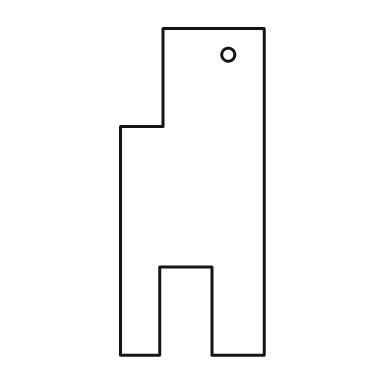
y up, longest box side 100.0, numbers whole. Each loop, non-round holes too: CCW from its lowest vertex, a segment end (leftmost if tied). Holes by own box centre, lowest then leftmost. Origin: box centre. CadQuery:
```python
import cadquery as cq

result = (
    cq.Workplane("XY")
    .moveTo(-22.0, -50.0)
    .lineTo(-10.0, -50.0)
    .lineTo(-10.0, -23.0)
    .lineTo(6.0, -23.0)
    .lineTo(6.0, -50.0)
    .lineTo(22.0, -50.0)
    .lineTo(22.0, 50.0)
    .lineTo(-9.0, 50.0)
    .lineTo(-9.0, 20.0)
    .lineTo(-22.0, 20.0)
    .close()
    .moveTo(11.0, 42.0)
    .circle(2.0)
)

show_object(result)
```